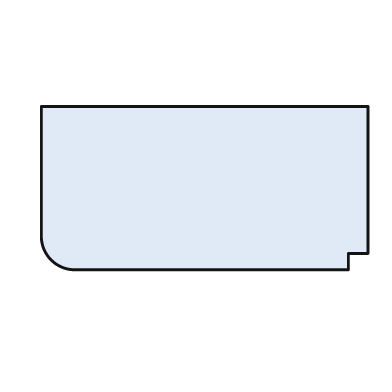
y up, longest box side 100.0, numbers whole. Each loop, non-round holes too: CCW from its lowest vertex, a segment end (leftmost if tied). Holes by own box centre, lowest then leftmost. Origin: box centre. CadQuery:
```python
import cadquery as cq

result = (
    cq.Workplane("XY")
    .moveTo(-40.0, -25.0)
    .lineTo(44.0, -25.0)
    .lineTo(44.0, -20.0)
    .lineTo(50.0, -20.0)
    .lineTo(50.0, 25.0)
    .lineTo(-50.0, 25.0)
    .lineTo(-50.0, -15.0)
    .threePointArc((-47.0, -22.0), (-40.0, -25.0))
    .close()
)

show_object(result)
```